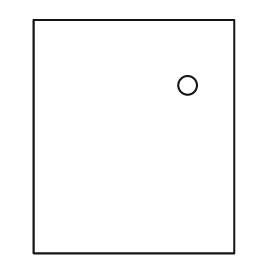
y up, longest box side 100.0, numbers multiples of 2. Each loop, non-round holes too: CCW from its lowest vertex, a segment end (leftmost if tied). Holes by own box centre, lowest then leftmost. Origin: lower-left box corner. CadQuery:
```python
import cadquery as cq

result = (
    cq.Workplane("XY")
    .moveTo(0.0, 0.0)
    .lineTo(86.0, 0.0)
    .lineTo(86.0, 100.0)
    .lineTo(0.0, 100.0)
    .close()
    .moveTo(66.0, 72.0)
    .circle(4.0)
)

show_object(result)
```